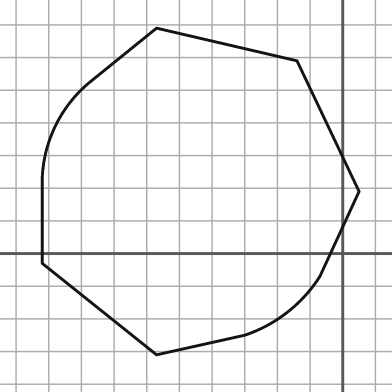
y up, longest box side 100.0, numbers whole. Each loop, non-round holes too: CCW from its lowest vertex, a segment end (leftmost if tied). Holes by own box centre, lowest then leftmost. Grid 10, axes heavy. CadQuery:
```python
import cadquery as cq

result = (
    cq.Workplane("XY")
    .moveTo(-57.0, -31.0)
    .lineTo(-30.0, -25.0)
    .threePointArc((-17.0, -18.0), (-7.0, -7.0))
    .lineTo(5.0, 19.0)
    .lineTo(-14.0, 59.0)
    .lineTo(-57.0, 69.0)
    .lineTo(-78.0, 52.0)
    .threePointArc((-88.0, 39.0), (-92.0, 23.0))
    .lineTo(-92.0, -3.0)
    .close()
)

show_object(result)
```